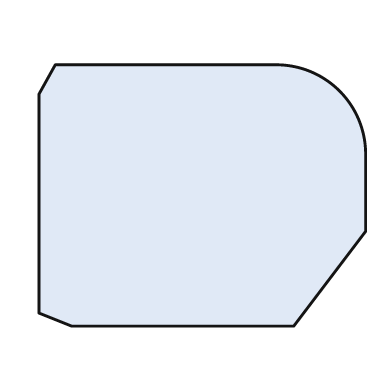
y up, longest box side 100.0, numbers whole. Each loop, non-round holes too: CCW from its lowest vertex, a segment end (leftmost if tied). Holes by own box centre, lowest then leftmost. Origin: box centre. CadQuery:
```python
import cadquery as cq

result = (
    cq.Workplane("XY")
    .moveTo(-40.0, -40.0)
    .lineTo(28.0, -40.0)
    .lineTo(50.0, -11.0)
    .lineTo(50.0, 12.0)
    .threePointArc((42.0, 32.0), (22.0, 40.0))
    .lineTo(-45.0, 40.0)
    .lineTo(-50.0, 31.0)
    .lineTo(-50.0, -36.0)
    .close()
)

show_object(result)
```